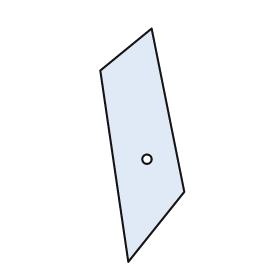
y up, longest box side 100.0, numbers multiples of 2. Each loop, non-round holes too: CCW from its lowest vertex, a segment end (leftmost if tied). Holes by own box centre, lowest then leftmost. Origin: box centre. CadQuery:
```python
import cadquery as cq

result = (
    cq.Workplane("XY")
    .moveTo(-6.0, -50.0)
    .lineTo(18.0, -20.0)
    .lineTo(4.0, 50.0)
    .lineTo(-18.0, 32.0)
    .close()
    .moveTo(2.0, -6.0)
    .circle(2.0)
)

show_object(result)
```